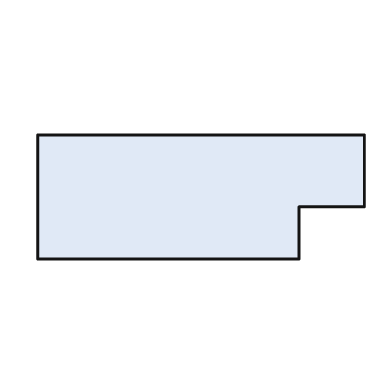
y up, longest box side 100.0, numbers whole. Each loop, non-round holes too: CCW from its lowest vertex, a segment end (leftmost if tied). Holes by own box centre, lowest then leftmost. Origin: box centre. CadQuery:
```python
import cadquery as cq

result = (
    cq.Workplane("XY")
    .moveTo(-50.0, -19.0)
    .lineTo(30.0, -19.0)
    .lineTo(30.0, -3.0)
    .lineTo(50.0, -3.0)
    .lineTo(50.0, 19.0)
    .lineTo(-50.0, 19.0)
    .close()
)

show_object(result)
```